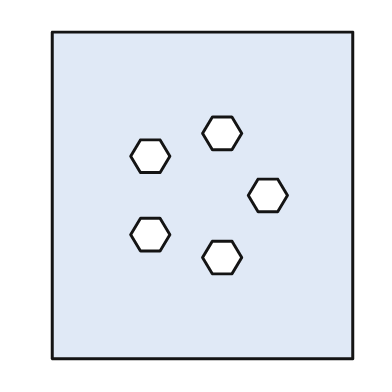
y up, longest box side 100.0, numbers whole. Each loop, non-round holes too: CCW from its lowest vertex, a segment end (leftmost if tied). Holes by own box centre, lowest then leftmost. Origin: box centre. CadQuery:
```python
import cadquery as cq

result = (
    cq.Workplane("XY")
    .moveTo(-46.0, -50.0)
    .lineTo(46.0, -50.0)
    .lineTo(46.0, 50.0)
    .lineTo(-46.0, 50.0)
    .close()
    .moveTo(3.0, -24.0)
    .lineTo(9.0, -24.0)
    .lineTo(12.0, -19.0)
    .lineTo(9.0, -14.0)
    .lineTo(3.0, -14.0)
    .lineTo(0.0, -19.0)
    .close()
    .moveTo(-19.0, -17.0)
    .lineTo(-13.0, -17.0)
    .lineTo(-10.0, -12.0)
    .lineTo(-13.0, -7.0)
    .lineTo(-19.0, -7.0)
    .lineTo(-22.0, -12.0)
    .close()
    .moveTo(17.0, -5.0)
    .lineTo(23.0, -5.0)
    .lineTo(26.0, 0.0)
    .lineTo(23.0, 5.0)
    .lineTo(17.0, 5.0)
    .lineTo(14.0, 0.0)
    .close()
    .moveTo(-19.0, 7.0)
    .lineTo(-13.0, 7.0)
    .lineTo(-10.0, 12.0)
    .lineTo(-13.0, 17.0)
    .lineTo(-19.0, 17.0)
    .lineTo(-22.0, 12.0)
    .close()
    .moveTo(3.0, 14.0)
    .lineTo(9.0, 14.0)
    .lineTo(12.0, 19.0)
    .lineTo(9.0, 24.0)
    .lineTo(3.0, 24.0)
    .lineTo(0.0, 19.0)
    .close()
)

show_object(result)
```